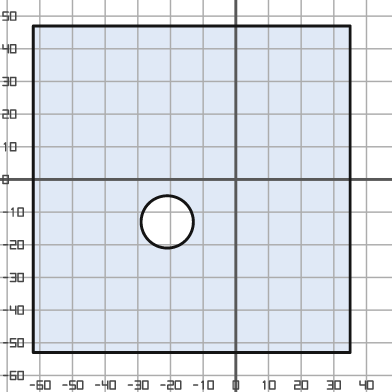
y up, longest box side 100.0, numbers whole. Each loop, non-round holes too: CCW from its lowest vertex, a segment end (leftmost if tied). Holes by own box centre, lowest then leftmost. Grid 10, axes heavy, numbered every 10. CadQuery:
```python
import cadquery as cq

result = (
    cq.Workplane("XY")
    .moveTo(-62.0, -53.0)
    .lineTo(35.0, -53.0)
    .lineTo(35.0, 47.0)
    .lineTo(-62.0, 47.0)
    .close()
    .moveTo(-21.0, -13.0)
    .circle(8.0)
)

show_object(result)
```